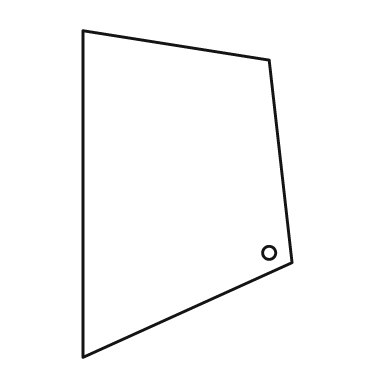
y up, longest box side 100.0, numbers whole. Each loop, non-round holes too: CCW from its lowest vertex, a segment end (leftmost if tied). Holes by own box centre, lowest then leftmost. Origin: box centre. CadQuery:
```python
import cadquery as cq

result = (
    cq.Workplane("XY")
    .moveTo(-32.0, -50.0)
    .lineTo(32.0, -21.0)
    .lineTo(25.0, 41.0)
    .lineTo(-32.0, 50.0)
    .close()
    .moveTo(25.0, -18.0)
    .circle(2.0)
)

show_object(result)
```